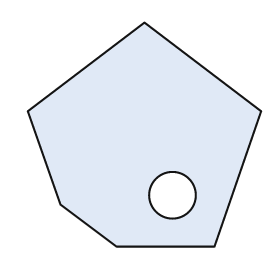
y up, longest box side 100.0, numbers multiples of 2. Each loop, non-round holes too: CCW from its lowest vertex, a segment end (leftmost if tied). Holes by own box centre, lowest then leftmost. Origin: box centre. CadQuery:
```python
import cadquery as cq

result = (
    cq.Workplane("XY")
    .moveTo(-12.0, -48.0)
    .lineTo(30.0, -48.0)
    .lineTo(50.0, 10.0)
    .lineTo(0.0, 48.0)
    .lineTo(-50.0, 10.0)
    .lineTo(-36.0, -30.0)
    .close()
    .moveTo(12.0, -26.0)
    .circle(10.0)
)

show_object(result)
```